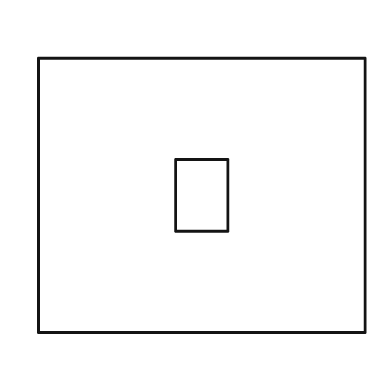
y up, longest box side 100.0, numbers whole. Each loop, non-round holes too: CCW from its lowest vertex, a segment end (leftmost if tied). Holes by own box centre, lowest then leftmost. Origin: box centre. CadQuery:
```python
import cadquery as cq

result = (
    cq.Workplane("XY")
    .moveTo(-50.0, -42.0)
    .lineTo(50.0, -42.0)
    .lineTo(50.0, 42.0)
    .lineTo(-50.0, 42.0)
    .close()
    .moveTo(-8.0, -11.0)
    .lineTo(8.0, -11.0)
    .lineTo(8.0, 11.0)
    .lineTo(-8.0, 11.0)
    .close()
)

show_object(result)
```